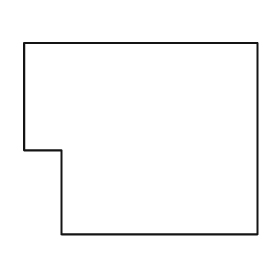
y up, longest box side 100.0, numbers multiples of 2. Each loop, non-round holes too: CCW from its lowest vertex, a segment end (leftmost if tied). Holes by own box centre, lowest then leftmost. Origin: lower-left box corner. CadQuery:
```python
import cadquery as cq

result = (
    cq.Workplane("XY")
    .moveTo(16.0, 0.0)
    .lineTo(100.0, 0.0)
    .lineTo(100.0, 82.0)
    .lineTo(0.0, 82.0)
    .lineTo(0.0, 36.0)
    .lineTo(16.0, 36.0)
    .close()
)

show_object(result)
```